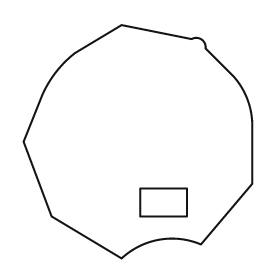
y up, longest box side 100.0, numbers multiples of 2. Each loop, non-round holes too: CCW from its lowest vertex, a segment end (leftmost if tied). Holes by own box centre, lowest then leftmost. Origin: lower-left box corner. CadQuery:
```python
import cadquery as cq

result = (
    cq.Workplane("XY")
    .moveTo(42.0, 0.0)
    .threePointArc((58.0, 8.0), (76.0, 6.0))
    .lineTo(98.0, 32.0)
    .lineTo(98.0, 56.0)
    .threePointArc((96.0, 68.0), (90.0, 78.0))
    .lineTo(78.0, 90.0)
    .threePointArc((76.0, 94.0), (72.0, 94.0))
    .lineTo(42.0, 100.0)
    .lineTo(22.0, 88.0)
    .threePointArc((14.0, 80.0), (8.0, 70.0))
    .lineTo(0.0, 50.0)
    .lineTo(12.0, 18.0)
    .close()
    .moveTo(50.0, 18.0)
    .lineTo(70.0, 18.0)
    .lineTo(70.0, 30.0)
    .lineTo(50.0, 30.0)
    .close()
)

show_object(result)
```